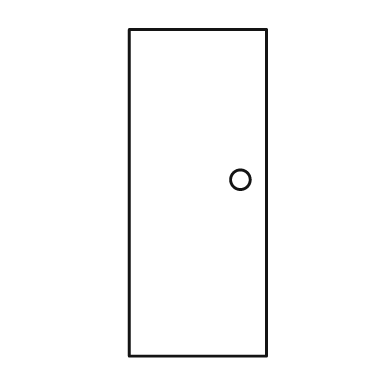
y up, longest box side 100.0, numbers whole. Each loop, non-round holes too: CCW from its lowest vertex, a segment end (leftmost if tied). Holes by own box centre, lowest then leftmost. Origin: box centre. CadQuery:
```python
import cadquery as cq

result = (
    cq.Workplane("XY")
    .moveTo(-21.0, -50.0)
    .lineTo(21.0, -50.0)
    .lineTo(21.0, 50.0)
    .lineTo(-21.0, 50.0)
    .close()
    .moveTo(13.0, 4.0)
    .circle(3.0)
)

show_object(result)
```